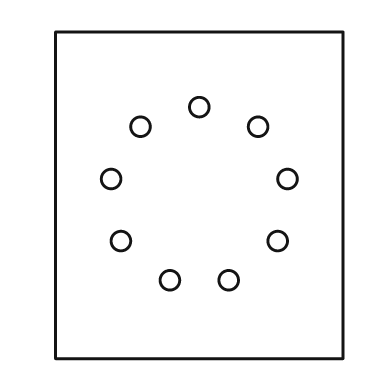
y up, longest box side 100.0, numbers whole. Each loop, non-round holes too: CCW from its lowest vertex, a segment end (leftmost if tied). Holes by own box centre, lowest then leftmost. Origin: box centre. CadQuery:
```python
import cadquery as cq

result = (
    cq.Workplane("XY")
    .moveTo(-44.0, -50.0)
    .lineTo(44.0, -50.0)
    .lineTo(44.0, 50.0)
    .lineTo(-44.0, 50.0)
    .close()
    .moveTo(-9.0, -26.0)
    .circle(3.0)
    .moveTo(9.0, -26.0)
    .circle(3.0)
    .moveTo(-24.0, -14.0)
    .circle(3.0)
    .moveTo(24.0, -14.0)
    .circle(3.0)
    .moveTo(-27.0, 5.0)
    .circle(3.0)
    .moveTo(27.0, 5.0)
    .circle(3.0)
    .moveTo(-18.0, 21.0)
    .circle(3.0)
    .moveTo(18.0, 21.0)
    .circle(3.0)
    .moveTo(0.0, 27.0)
    .circle(3.0)
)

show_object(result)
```